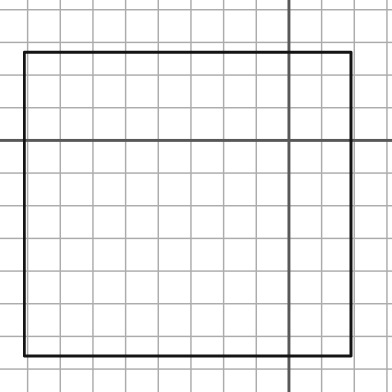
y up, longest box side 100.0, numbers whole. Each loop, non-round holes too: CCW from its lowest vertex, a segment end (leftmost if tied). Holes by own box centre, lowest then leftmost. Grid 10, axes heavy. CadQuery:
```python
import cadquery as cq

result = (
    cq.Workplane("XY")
    .moveTo(-81.0, -66.0)
    .lineTo(19.0, -66.0)
    .lineTo(19.0, 27.0)
    .lineTo(-81.0, 27.0)
    .close()
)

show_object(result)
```